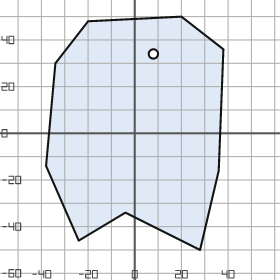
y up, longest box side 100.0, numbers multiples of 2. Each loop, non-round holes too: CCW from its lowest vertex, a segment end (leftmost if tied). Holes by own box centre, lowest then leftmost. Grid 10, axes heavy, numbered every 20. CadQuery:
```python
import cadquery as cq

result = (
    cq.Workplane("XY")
    .moveTo(28.0, -50.0)
    .lineTo(36.0, -16.0)
    .lineTo(38.0, 36.0)
    .lineTo(20.0, 50.0)
    .lineTo(-20.0, 48.0)
    .lineTo(-34.0, 30.0)
    .lineTo(-38.0, -14.0)
    .lineTo(-24.0, -46.0)
    .lineTo(-4.0, -34.0)
    .close()
    .moveTo(8.0, 34.0)
    .circle(2.0)
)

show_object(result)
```